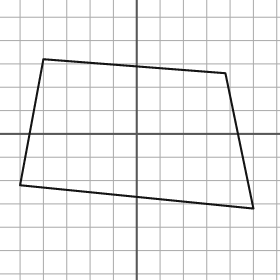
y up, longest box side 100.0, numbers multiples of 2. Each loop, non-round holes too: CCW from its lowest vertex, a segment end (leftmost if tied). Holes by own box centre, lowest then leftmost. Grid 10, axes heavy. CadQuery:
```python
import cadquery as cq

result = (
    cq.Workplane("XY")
    .moveTo(50.0, -32.0)
    .lineTo(38.0, 26.0)
    .lineTo(-40.0, 32.0)
    .lineTo(-50.0, -22.0)
    .close()
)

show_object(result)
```